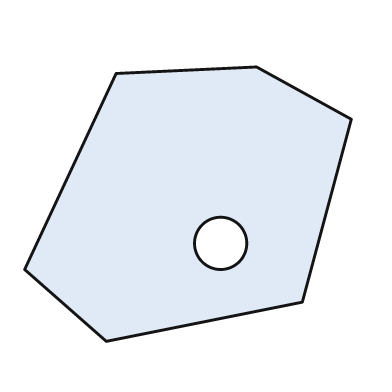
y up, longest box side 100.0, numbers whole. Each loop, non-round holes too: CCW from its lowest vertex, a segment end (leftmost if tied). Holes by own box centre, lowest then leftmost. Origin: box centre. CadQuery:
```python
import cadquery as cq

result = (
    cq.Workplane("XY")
    .moveTo(-25.0, -42.0)
    .lineTo(35.0, -30.0)
    .lineTo(50.0, 26.0)
    .lineTo(21.0, 42.0)
    .lineTo(-22.0, 40.0)
    .lineTo(-50.0, -20.0)
    .close()
    .moveTo(10.0, -12.0)
    .circle(8.0)
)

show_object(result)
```